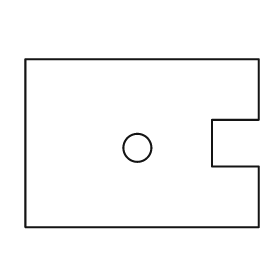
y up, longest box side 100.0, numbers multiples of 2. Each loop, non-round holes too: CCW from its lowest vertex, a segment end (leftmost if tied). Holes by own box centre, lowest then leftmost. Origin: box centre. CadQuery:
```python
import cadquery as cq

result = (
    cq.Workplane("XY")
    .moveTo(-50.0, -36.0)
    .lineTo(50.0, -36.0)
    .lineTo(50.0, -10.0)
    .lineTo(30.0, -10.0)
    .lineTo(30.0, 10.0)
    .lineTo(50.0, 10.0)
    .lineTo(50.0, 36.0)
    .lineTo(-50.0, 36.0)
    .close()
    .moveTo(-2.0, -2.0)
    .circle(6.0)
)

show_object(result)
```